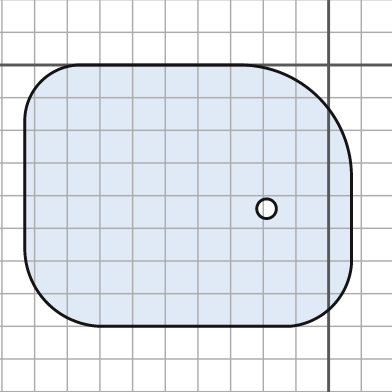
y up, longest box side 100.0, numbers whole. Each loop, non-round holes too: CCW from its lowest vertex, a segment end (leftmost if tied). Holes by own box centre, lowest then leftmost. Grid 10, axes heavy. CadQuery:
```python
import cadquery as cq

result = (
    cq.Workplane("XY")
    .moveTo(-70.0, -80.0)
    .lineTo(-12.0, -80.0)
    .threePointArc((1.0, -74.0), (7.0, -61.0))
    .lineTo(7.0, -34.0)
    .threePointArc((-3.0, -10.0), (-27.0, 0.0))
    .lineTo(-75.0, 0.0)
    .threePointArc((-88.0, -5.0), (-93.0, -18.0))
    .lineTo(-93.0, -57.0)
    .threePointArc((-86.0, -73.0), (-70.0, -80.0))
    .close()
    .moveTo(-19.0, -44.0)
    .circle(3.0)
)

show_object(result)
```